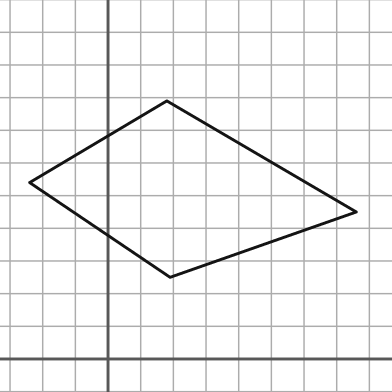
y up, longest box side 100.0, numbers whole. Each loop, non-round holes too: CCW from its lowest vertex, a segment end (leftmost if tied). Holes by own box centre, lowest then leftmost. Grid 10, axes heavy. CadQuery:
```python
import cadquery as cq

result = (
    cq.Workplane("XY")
    .moveTo(19.0, 25.0)
    .lineTo(76.0, 45.0)
    .lineTo(18.0, 79.0)
    .lineTo(-24.0, 54.0)
    .close()
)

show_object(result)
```